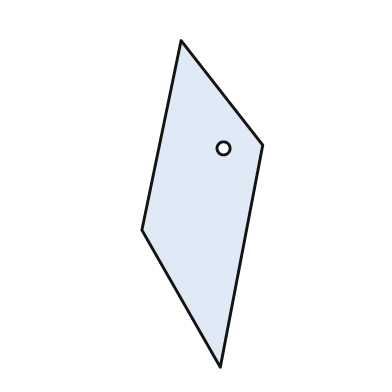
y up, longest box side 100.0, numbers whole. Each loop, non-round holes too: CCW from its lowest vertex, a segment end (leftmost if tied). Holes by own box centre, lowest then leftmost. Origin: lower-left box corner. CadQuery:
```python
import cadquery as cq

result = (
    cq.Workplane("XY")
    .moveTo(24.0, 0.0)
    .lineTo(37.0, 68.0)
    .lineTo(12.0, 100.0)
    .lineTo(0.0, 42.0)
    .close()
    .moveTo(25.0, 67.0)
    .circle(2.0)
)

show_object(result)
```